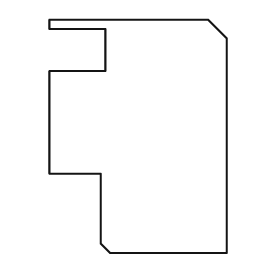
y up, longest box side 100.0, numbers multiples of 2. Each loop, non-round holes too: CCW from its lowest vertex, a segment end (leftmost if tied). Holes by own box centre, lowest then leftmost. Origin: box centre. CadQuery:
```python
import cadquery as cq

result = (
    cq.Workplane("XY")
    .moveTo(-12.0, -50.0)
    .lineTo(38.0, -50.0)
    .lineTo(38.0, 42.0)
    .lineTo(30.0, 50.0)
    .lineTo(-38.0, 50.0)
    .lineTo(-38.0, 46.0)
    .lineTo(-14.0, 46.0)
    .lineTo(-14.0, 28.0)
    .lineTo(-38.0, 28.0)
    .lineTo(-38.0, -16.0)
    .lineTo(-16.0, -16.0)
    .lineTo(-16.0, -46.0)
    .close()
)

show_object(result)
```